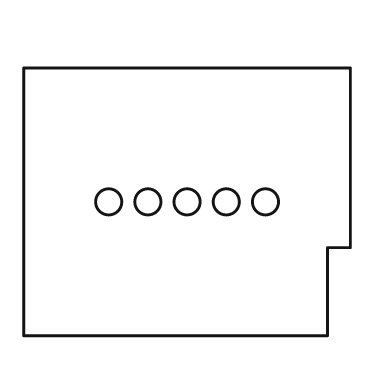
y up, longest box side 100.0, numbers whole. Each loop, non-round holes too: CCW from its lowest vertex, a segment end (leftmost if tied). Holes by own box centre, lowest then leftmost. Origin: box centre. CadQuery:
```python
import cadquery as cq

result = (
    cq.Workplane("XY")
    .moveTo(-50.0, -41.0)
    .lineTo(43.0, -41.0)
    .lineTo(43.0, -14.0)
    .lineTo(50.0, -14.0)
    .lineTo(50.0, 41.0)
    .lineTo(-50.0, 41.0)
    .close()
    .moveTo(-24.0, 0.0)
    .circle(4.0)
    .moveTo(-12.0, 0.0)
    .circle(4.0)
    .moveTo(0.0, 0.0)
    .circle(4.0)
    .moveTo(12.0, 0.0)
    .circle(4.0)
    .moveTo(24.0, 0.0)
    .circle(4.0)
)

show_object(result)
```